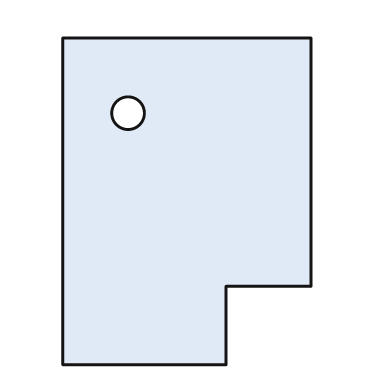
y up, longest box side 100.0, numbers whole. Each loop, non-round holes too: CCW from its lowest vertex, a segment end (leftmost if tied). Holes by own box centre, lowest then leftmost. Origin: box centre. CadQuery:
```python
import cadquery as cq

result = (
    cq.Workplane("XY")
    .moveTo(-38.0, -50.0)
    .lineTo(12.0, -50.0)
    .lineTo(12.0, -26.0)
    .lineTo(38.0, -26.0)
    .lineTo(38.0, 50.0)
    .lineTo(-38.0, 50.0)
    .close()
    .moveTo(-18.0, 27.0)
    .circle(5.0)
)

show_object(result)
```